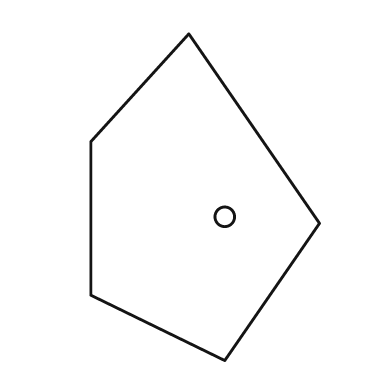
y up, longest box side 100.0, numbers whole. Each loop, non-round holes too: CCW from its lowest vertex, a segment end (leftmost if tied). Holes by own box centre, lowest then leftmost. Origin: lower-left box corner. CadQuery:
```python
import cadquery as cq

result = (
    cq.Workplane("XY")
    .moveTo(41.0, 0.0)
    .lineTo(70.0, 42.0)
    .lineTo(30.0, 100.0)
    .lineTo(0.0, 67.0)
    .lineTo(0.0, 20.0)
    .close()
    .moveTo(41.0, 44.0)
    .circle(3.0)
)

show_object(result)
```